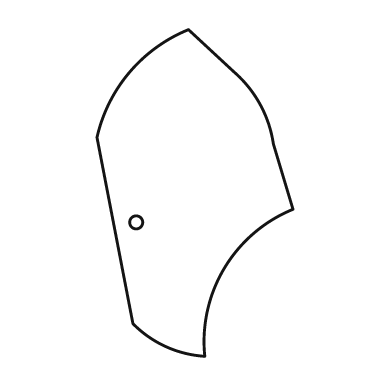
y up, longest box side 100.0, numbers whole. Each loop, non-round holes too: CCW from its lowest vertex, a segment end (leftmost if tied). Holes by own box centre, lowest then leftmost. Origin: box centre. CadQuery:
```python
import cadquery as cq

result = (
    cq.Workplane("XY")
    .moveTo(3.0, -50.0)
    .threePointArc((9.0, -23.0), (30.0, -5.0))
    .lineTo(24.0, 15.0)
    .threePointArc((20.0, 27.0), (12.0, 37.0))
    .lineTo(-2.0, 50.0)
    .threePointArc((-20.0, 37.0), (-30.0, 17.0))
    .lineTo(-19.0, -40.0)
    .threePointArc((-9.0, -47.0), (3.0, -50.0))
    .close()
    .moveTo(-18.0, -9.0)
    .circle(2.0)
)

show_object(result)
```